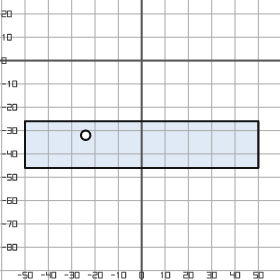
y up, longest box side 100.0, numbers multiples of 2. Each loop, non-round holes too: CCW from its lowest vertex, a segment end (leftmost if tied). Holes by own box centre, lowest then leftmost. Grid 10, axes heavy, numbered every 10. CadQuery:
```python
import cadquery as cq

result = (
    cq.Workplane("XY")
    .moveTo(-50.0, -46.0)
    .lineTo(50.0, -46.0)
    .lineTo(50.0, -26.0)
    .lineTo(-50.0, -26.0)
    .close()
    .moveTo(-24.0, -32.0)
    .circle(2.0)
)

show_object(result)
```